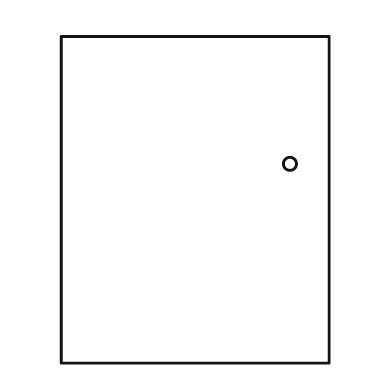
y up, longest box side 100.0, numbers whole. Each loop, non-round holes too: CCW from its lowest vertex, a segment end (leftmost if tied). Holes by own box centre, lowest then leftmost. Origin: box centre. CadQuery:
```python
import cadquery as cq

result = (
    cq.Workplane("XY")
    .moveTo(-41.0, -50.0)
    .lineTo(41.0, -50.0)
    .lineTo(41.0, 50.0)
    .lineTo(-41.0, 50.0)
    .close()
    .moveTo(29.0, 11.0)
    .circle(2.0)
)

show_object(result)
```